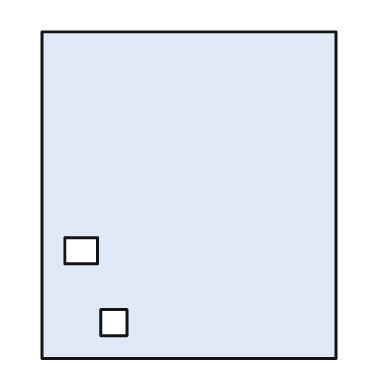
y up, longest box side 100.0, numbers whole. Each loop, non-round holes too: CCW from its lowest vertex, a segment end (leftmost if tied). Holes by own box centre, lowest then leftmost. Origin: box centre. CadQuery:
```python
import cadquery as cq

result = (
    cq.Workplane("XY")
    .moveTo(-45.0, -50.0)
    .lineTo(45.0, -50.0)
    .lineTo(45.0, 50.0)
    .lineTo(-45.0, 50.0)
    .close()
    .moveTo(-27.0, -43.0)
    .lineTo(-19.0, -43.0)
    .lineTo(-19.0, -35.0)
    .lineTo(-27.0, -35.0)
    .close()
    .moveTo(-38.0, -21.0)
    .lineTo(-28.0, -21.0)
    .lineTo(-28.0, -13.0)
    .lineTo(-38.0, -13.0)
    .close()
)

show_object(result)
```